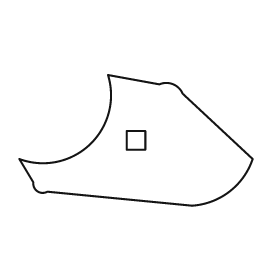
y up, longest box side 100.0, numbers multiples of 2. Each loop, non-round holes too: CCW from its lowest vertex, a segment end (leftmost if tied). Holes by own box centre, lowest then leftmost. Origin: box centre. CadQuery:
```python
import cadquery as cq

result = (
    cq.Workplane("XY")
    .moveTo(24.0, -28.0)
    .threePointArc((40.0, -22.0), (50.0, -8.0))
    .lineTo(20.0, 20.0)
    .threePointArc((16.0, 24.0), (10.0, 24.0))
    .lineTo(-12.0, 28.0)
    .threePointArc((-20.0, -2.0), (-50.0, -8.0))
    .lineTo(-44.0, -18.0)
    .threePointArc((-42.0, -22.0), (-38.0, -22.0))
    .close()
    .moveTo(-4.0, -4.0)
    .lineTo(4.0, -4.0)
    .lineTo(4.0, 4.0)
    .lineTo(-4.0, 4.0)
    .close()
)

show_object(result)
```